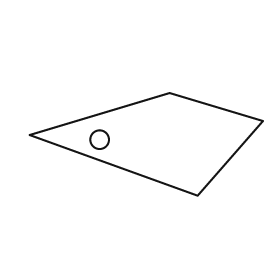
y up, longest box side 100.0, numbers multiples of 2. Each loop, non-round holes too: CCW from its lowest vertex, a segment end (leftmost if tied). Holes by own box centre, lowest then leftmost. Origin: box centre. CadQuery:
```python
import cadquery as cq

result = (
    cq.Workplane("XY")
    .moveTo(22.0, -22.0)
    .lineTo(50.0, 10.0)
    .lineTo(10.0, 22.0)
    .lineTo(-50.0, 4.0)
    .close()
    .moveTo(-20.0, 2.0)
    .circle(4.0)
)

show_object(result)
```